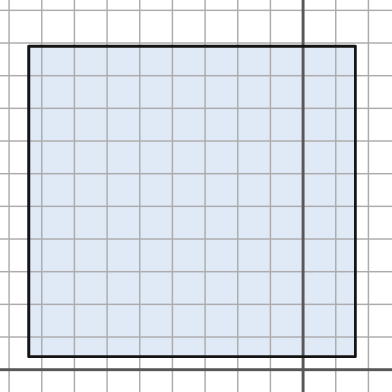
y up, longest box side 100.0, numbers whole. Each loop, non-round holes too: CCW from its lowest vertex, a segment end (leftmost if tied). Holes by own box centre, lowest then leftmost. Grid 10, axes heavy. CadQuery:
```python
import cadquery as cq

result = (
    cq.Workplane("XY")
    .moveTo(-84.0, 4.0)
    .lineTo(16.0, 4.0)
    .lineTo(16.0, 99.0)
    .lineTo(-84.0, 99.0)
    .close()
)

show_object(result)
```